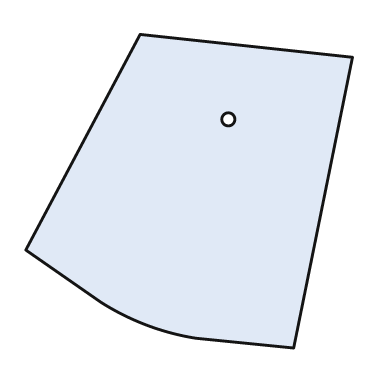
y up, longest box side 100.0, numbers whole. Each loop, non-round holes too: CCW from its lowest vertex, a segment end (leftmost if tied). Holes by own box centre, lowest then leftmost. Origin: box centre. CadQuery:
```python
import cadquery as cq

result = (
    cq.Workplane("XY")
    .moveTo(32.0, -48.0)
    .lineTo(50.0, 41.0)
    .lineTo(-15.0, 48.0)
    .lineTo(-50.0, -18.0)
    .lineTo(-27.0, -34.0)
    .threePointArc((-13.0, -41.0), (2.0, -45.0))
    .close()
    .moveTo(12.0, 22.0)
    .circle(2.0)
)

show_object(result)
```